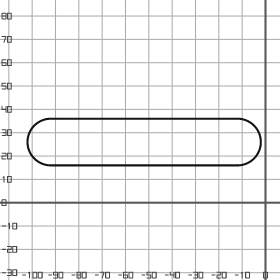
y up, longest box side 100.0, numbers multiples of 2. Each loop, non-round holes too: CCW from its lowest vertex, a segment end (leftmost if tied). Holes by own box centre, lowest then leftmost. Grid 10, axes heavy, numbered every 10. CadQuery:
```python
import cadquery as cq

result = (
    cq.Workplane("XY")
    .moveTo(-92.0, 16.0)
    .lineTo(-12.0, 16.0)
    .threePointArc((-2.0, 26.0), (-12.0, 36.0))
    .lineTo(-92.0, 36.0)
    .threePointArc((-102.0, 26.0), (-92.0, 16.0))
    .close()
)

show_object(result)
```